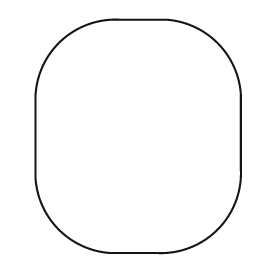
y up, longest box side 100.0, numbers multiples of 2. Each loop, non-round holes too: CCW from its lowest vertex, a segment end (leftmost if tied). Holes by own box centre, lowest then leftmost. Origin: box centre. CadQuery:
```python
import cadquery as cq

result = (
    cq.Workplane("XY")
    .moveTo(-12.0, -50.0)
    .lineTo(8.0, -50.0)
    .threePointArc((34.0, -40.0), (44.0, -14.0))
    .lineTo(44.0, 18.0)
    .threePointArc((34.0, 40.0), (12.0, 50.0))
    .lineTo(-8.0, 50.0)
    .threePointArc((-34.0, 40.0), (-44.0, 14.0))
    .lineTo(-44.0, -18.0)
    .threePointArc((-34.0, -40.0), (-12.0, -50.0))
    .close()
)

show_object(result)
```